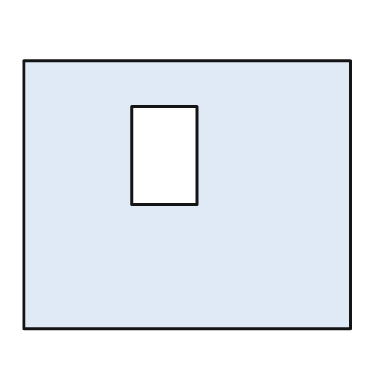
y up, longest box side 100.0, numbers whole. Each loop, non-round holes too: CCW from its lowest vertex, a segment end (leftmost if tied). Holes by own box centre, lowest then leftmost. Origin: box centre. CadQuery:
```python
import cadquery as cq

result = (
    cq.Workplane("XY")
    .moveTo(-50.0, -41.0)
    .lineTo(50.0, -41.0)
    .lineTo(50.0, 41.0)
    .lineTo(-50.0, 41.0)
    .close()
    .moveTo(-17.0, -3.0)
    .lineTo(3.0, -3.0)
    .lineTo(3.0, 27.0)
    .lineTo(-17.0, 27.0)
    .close()
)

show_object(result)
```